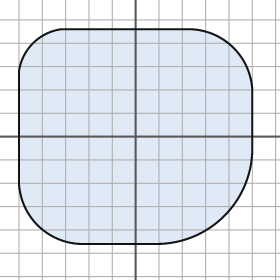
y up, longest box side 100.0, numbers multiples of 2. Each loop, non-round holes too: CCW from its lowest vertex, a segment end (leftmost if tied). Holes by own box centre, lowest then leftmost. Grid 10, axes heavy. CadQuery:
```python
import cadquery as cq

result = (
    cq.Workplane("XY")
    .moveTo(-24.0, -46.0)
    .lineTo(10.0, -46.0)
    .threePointArc((38.0, -34.0), (50.0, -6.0))
    .lineTo(50.0, 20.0)
    .threePointArc((42.0, 38.0), (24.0, 46.0))
    .lineTo(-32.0, 46.0)
    .threePointArc((-44.0, 40.0), (-50.0, 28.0))
    .lineTo(-50.0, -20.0)
    .threePointArc((-42.0, -38.0), (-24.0, -46.0))
    .close()
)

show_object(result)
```